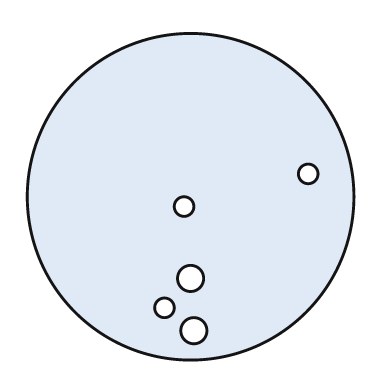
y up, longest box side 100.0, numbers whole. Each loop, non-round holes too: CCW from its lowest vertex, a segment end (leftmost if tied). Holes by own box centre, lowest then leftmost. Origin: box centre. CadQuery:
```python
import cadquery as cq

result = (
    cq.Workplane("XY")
    .moveTo(0.0, 0.0)
    .circle(50.0)
    .moveTo(1.0, -41.0)
    .circle(4.0)
    .moveTo(-8.0, -34.0)
    .circle(3.0)
    .moveTo(0.0, -25.0)
    .circle(4.0)
    .moveTo(-2.0, -3.0)
    .circle(3.0)
    .moveTo(36.0, 7.0)
    .circle(3.0)
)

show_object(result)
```